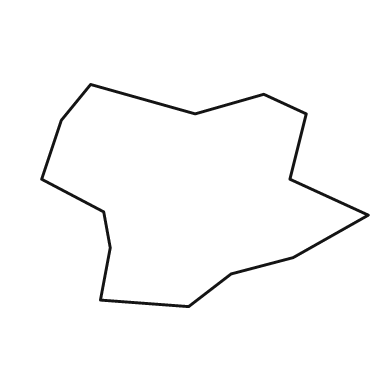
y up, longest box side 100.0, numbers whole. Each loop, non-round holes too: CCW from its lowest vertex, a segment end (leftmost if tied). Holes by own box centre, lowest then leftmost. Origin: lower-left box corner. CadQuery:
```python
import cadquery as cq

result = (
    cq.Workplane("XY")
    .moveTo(45.0, 0.0)
    .lineTo(58.0, 10.0)
    .lineTo(77.0, 15.0)
    .lineTo(100.0, 28.0)
    .lineTo(76.0, 39.0)
    .lineTo(81.0, 59.0)
    .lineTo(68.0, 65.0)
    .lineTo(47.0, 59.0)
    .lineTo(15.0, 68.0)
    .lineTo(6.0, 57.0)
    .lineTo(0.0, 39.0)
    .lineTo(19.0, 29.0)
    .lineTo(21.0, 18.0)
    .lineTo(18.0, 2.0)
    .close()
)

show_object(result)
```